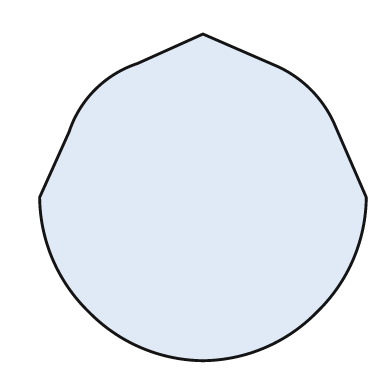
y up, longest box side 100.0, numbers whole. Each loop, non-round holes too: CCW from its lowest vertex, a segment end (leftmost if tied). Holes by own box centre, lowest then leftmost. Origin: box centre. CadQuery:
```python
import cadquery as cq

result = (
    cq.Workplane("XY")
    .moveTo(0.0, -50.0)
    .threePointArc((19.0, -46.0), (35.0, -35.0))
    .threePointArc((46.0, -19.0), (50.0, 0.0))
    .lineTo(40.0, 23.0)
    .threePointArc((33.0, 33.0), (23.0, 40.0))
    .lineTo(0.0, 50.0)
    .lineTo(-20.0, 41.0)
    .threePointArc((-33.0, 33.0), (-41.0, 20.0))
    .lineTo(-50.0, 0.0)
    .threePointArc((-46.0, -19.0), (-35.0, -35.0))
    .threePointArc((-19.0, -46.0), (0.0, -50.0))
    .close()
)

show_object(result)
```